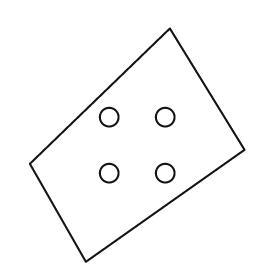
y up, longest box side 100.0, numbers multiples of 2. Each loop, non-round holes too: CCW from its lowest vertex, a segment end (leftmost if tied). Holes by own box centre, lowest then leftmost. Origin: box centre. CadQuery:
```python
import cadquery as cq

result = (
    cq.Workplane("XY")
    .moveTo(-22.0, -50.0)
    .lineTo(46.0, -2.0)
    .lineTo(14.0, 50.0)
    .lineTo(-46.0, -8.0)
    .close()
    .moveTo(-12.0, -12.0)
    .circle(4.0)
    .moveTo(12.0, -12.0)
    .circle(4.0)
    .moveTo(-12.0, 12.0)
    .circle(4.0)
    .moveTo(12.0, 12.0)
    .circle(4.0)
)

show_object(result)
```